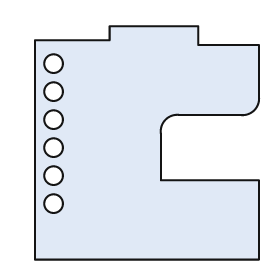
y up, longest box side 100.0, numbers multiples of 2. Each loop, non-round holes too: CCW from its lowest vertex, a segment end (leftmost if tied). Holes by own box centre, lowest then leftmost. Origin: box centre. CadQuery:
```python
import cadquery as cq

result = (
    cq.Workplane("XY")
    .moveTo(-48.0, -50.0)
    .lineTo(48.0, -50.0)
    .lineTo(48.0, -16.0)
    .lineTo(6.0, -16.0)
    .lineTo(6.0, 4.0)
    .threePointArc((8.0, 10.0), (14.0, 12.0))
    .lineTo(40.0, 12.0)
    .threePointArc((46.0, 14.0), (48.0, 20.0))
    .lineTo(48.0, 42.0)
    .lineTo(22.0, 42.0)
    .lineTo(22.0, 50.0)
    .lineTo(-16.0, 50.0)
    .lineTo(-16.0, 44.0)
    .lineTo(-48.0, 44.0)
    .close()
    .moveTo(-40.0, -26.0)
    .circle(4.0)
    .moveTo(-40.0, -14.0)
    .circle(4.0)
    .moveTo(-40.0, -2.0)
    .circle(4.0)
    .moveTo(-40.0, 10.0)
    .circle(4.0)
    .moveTo(-40.0, 22.0)
    .circle(4.0)
    .moveTo(-40.0, 34.0)
    .circle(4.0)
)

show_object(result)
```